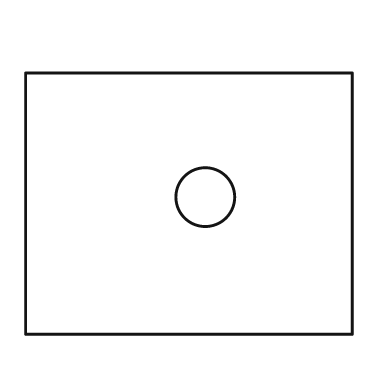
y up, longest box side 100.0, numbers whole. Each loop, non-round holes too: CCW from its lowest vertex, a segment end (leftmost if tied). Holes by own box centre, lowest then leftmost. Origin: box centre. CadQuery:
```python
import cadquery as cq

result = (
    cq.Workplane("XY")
    .moveTo(-50.0, -40.0)
    .lineTo(50.0, -40.0)
    .lineTo(50.0, 40.0)
    .lineTo(-50.0, 40.0)
    .close()
    .moveTo(5.0, 2.0)
    .circle(9.0)
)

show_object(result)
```